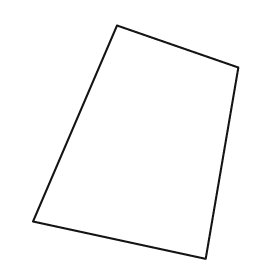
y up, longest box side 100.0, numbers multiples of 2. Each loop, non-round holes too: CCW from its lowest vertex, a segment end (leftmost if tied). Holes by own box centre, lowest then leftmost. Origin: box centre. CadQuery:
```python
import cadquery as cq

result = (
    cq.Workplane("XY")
    .moveTo(30.0, -50.0)
    .lineTo(44.0, 32.0)
    .lineTo(-8.0, 50.0)
    .lineTo(-44.0, -34.0)
    .close()
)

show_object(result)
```